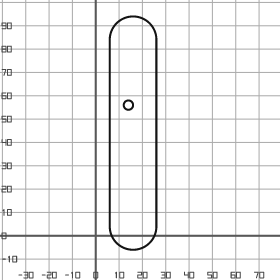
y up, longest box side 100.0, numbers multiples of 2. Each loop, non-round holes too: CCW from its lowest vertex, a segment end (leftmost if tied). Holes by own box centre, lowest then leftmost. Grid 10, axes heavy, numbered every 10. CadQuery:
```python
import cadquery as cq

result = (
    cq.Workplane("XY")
    .moveTo(6.0, 4.0)
    .threePointArc((16.0, -6.0), (26.0, 4.0))
    .lineTo(26.0, 84.0)
    .threePointArc((16.0, 94.0), (6.0, 84.0))
    .close()
    .moveTo(14.0, 56.0)
    .circle(2.0)
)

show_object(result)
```